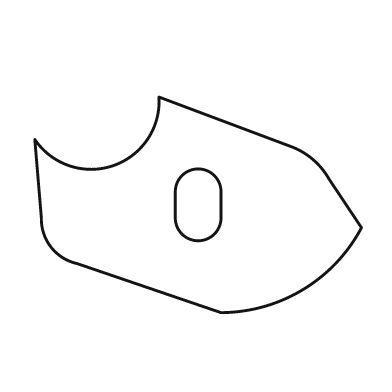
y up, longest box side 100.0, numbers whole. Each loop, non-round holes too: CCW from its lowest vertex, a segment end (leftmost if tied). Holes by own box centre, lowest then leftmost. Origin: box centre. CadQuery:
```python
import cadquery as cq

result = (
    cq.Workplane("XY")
    .moveTo(7.0, -33.0)
    .threePointArc((32.0, -26.0), (50.0, -7.0))
    .lineTo(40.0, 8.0)
    .threePointArc((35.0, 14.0), (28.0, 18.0))
    .lineTo(-12.0, 33.0)
    .threePointArc((-26.0, 12.0), (-50.0, 20.0))
    .lineTo(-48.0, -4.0)
    .threePointArc((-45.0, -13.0), (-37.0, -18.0))
    .close()
    .moveTo(-7.0, -4.0)
    .threePointArc((0.0, -11.0), (7.0, -4.0))
    .lineTo(7.0, 4.0)
    .threePointArc((0.0, 11.0), (-7.0, 4.0))
    .close()
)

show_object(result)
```